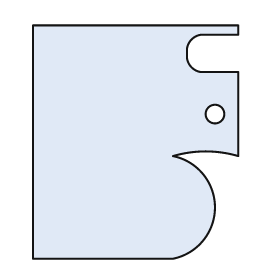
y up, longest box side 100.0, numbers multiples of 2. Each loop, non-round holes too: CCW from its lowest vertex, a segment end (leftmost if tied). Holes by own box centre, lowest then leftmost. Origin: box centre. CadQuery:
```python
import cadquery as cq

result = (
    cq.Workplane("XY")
    .moveTo(-44.0, -50.0)
    .lineTo(16.0, -50.0)
    .threePointArc((34.0, -28.0), (16.0, -6.0))
    .threePointArc((30.0, -4.0), (44.0, -6.0))
    .lineTo(44.0, 30.0)
    .lineTo(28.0, 30.0)
    .threePointArc((24.0, 32.0), (22.0, 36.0))
    .lineTo(22.0, 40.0)
    .threePointArc((24.0, 44.0), (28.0, 46.0))
    .lineTo(44.0, 46.0)
    .lineTo(44.0, 50.0)
    .lineTo(-44.0, 50.0)
    .close()
    .moveTo(34.0, 12.0)
    .circle(4.0)
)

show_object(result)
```